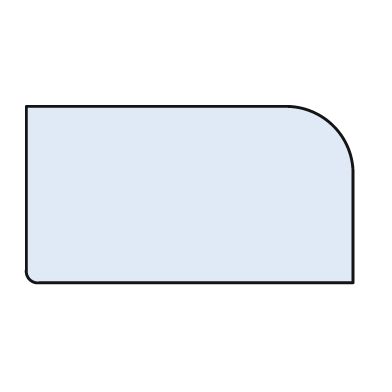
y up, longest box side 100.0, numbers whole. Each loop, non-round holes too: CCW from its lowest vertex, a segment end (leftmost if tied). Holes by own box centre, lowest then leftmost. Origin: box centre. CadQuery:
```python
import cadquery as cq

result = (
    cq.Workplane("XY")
    .moveTo(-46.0, -27.0)
    .lineTo(50.0, -27.0)
    .lineTo(50.0, 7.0)
    .threePointArc((44.0, 21.0), (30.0, 27.0))
    .lineTo(-50.0, 27.0)
    .lineTo(-50.0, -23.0)
    .threePointArc((-49.0, -26.0), (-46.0, -27.0))
    .close()
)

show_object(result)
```